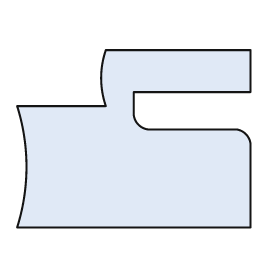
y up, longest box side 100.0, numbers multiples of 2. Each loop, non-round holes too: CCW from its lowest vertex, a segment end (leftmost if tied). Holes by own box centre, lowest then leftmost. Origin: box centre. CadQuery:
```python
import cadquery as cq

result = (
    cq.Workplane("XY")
    .moveTo(-50.0, -38.0)
    .lineTo(50.0, -38.0)
    .lineTo(50.0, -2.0)
    .threePointArc((48.0, 2.0), (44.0, 4.0))
    .lineTo(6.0, 4.0)
    .threePointArc((2.0, 6.0), (0.0, 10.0))
    .lineTo(0.0, 20.0)
    .lineTo(50.0, 20.0)
    .lineTo(50.0, 38.0)
    .lineTo(-12.0, 38.0)
    .threePointArc((-14.0, 26.0), (-12.0, 14.0))
    .lineTo(-50.0, 14.0)
    .threePointArc((-46.0, -12.0), (-50.0, -38.0))
    .close()
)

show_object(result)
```